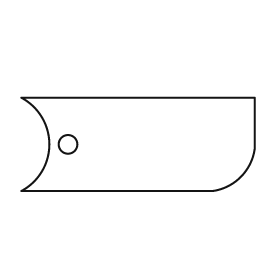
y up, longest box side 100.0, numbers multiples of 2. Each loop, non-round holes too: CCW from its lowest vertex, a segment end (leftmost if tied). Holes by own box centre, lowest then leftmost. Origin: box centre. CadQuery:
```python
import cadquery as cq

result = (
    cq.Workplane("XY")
    .moveTo(-50.0, -20.0)
    .lineTo(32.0, -20.0)
    .threePointArc((44.0, -14.0), (50.0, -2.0))
    .lineTo(50.0, 20.0)
    .lineTo(-50.0, 20.0)
    .threePointArc((-38.0, 0.0), (-50.0, -20.0))
    .close()
    .moveTo(-30.0, 0.0)
    .circle(4.0)
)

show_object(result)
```